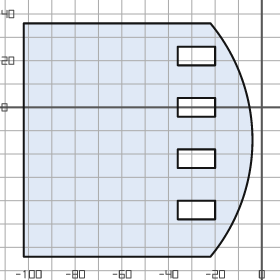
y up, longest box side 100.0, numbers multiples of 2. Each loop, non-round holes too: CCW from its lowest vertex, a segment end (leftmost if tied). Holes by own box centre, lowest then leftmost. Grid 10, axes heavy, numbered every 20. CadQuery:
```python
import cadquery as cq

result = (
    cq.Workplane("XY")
    .moveTo(-102.0, -64.0)
    .lineTo(-22.0, -64.0)
    .threePointArc((-4.0, -14.0), (-22.0, 36.0))
    .lineTo(-102.0, 36.0)
    .close()
    .moveTo(-36.0, -48.0)
    .lineTo(-20.0, -48.0)
    .lineTo(-20.0, -40.0)
    .lineTo(-36.0, -40.0)
    .close()
    .moveTo(-36.0, -26.0)
    .lineTo(-20.0, -26.0)
    .lineTo(-20.0, -18.0)
    .lineTo(-36.0, -18.0)
    .close()
    .moveTo(-36.0, -4.0)
    .lineTo(-20.0, -4.0)
    .lineTo(-20.0, 4.0)
    .lineTo(-36.0, 4.0)
    .close()
    .moveTo(-36.0, 18.0)
    .lineTo(-20.0, 18.0)
    .lineTo(-20.0, 26.0)
    .lineTo(-36.0, 26.0)
    .close()
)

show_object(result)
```